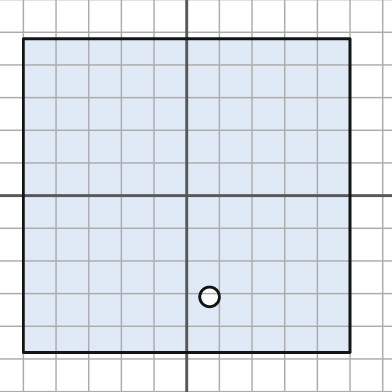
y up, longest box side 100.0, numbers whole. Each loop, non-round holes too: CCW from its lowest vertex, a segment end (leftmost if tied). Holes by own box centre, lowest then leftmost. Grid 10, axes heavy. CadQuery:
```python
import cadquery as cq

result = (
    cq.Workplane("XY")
    .moveTo(-50.0, -48.0)
    .lineTo(50.0, -48.0)
    .lineTo(50.0, 48.0)
    .lineTo(-50.0, 48.0)
    .close()
    .moveTo(7.0, -31.0)
    .circle(3.0)
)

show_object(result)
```